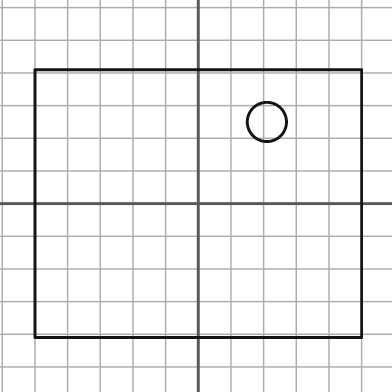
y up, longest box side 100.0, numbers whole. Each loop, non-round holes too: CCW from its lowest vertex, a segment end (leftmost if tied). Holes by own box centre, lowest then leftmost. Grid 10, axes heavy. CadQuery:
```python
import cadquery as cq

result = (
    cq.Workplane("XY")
    .moveTo(-50.0, -41.0)
    .lineTo(50.0, -41.0)
    .lineTo(50.0, 41.0)
    .lineTo(-50.0, 41.0)
    .close()
    .moveTo(21.0, 25.0)
    .circle(6.0)
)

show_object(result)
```